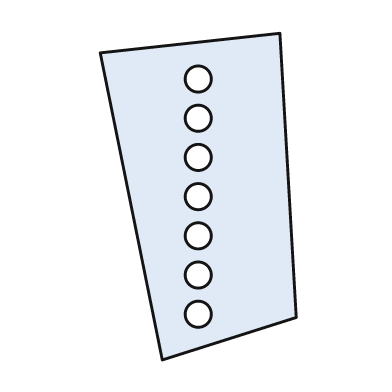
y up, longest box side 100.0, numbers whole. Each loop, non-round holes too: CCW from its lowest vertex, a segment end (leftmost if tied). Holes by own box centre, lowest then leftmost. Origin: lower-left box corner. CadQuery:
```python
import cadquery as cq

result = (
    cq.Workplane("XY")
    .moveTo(19.0, 0.0)
    .lineTo(60.0, 13.0)
    .lineTo(55.0, 100.0)
    .lineTo(0.0, 94.0)
    .close()
    .moveTo(30.0, 14.0)
    .circle(4.0)
    .moveTo(30.0, 26.0)
    .circle(4.0)
    .moveTo(30.0, 38.0)
    .circle(4.0)
    .moveTo(30.0, 50.0)
    .circle(4.0)
    .moveTo(30.0, 62.0)
    .circle(4.0)
    .moveTo(30.0, 74.0)
    .circle(4.0)
    .moveTo(30.0, 86.0)
    .circle(4.0)
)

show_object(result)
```